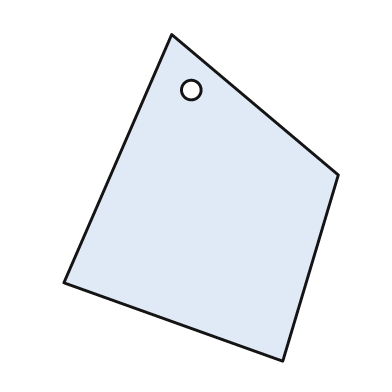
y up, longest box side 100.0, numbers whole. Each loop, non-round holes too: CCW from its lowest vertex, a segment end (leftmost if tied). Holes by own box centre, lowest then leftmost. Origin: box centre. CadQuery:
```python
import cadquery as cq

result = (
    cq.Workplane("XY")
    .moveTo(25.0, -50.0)
    .lineTo(42.0, 7.0)
    .lineTo(-9.0, 50.0)
    .lineTo(-42.0, -26.0)
    .close()
    .moveTo(-3.0, 33.0)
    .circle(3.0)
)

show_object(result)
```